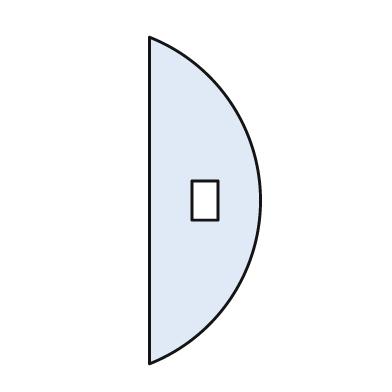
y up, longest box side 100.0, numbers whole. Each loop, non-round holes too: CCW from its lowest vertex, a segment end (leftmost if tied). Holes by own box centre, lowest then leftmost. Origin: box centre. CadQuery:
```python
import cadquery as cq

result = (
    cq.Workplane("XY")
    .moveTo(-17.0, -50.0)
    .threePointArc((17.0, 0.0), (-17.0, 50.0))
    .close()
    .moveTo(-4.0, -6.0)
    .lineTo(4.0, -6.0)
    .lineTo(4.0, 6.0)
    .lineTo(-4.0, 6.0)
    .close()
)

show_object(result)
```